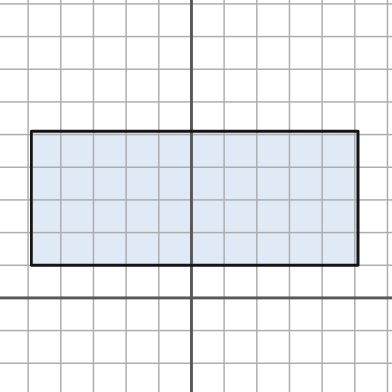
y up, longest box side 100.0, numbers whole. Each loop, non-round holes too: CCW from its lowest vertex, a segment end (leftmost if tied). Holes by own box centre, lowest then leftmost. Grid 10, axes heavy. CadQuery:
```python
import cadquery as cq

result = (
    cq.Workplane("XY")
    .moveTo(-49.0, 10.0)
    .lineTo(51.0, 10.0)
    .lineTo(51.0, 51.0)
    .lineTo(-49.0, 51.0)
    .close()
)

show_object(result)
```